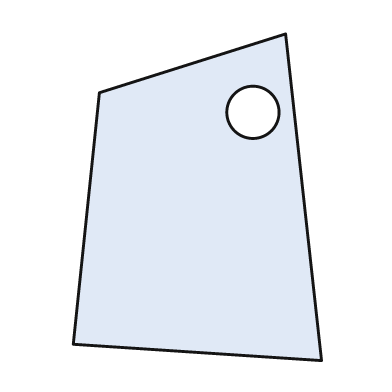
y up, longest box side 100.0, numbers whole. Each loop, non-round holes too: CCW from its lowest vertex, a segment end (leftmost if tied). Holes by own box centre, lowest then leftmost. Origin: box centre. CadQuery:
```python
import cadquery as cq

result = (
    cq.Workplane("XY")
    .moveTo(38.0, -50.0)
    .lineTo(27.0, 50.0)
    .lineTo(-30.0, 32.0)
    .lineTo(-38.0, -45.0)
    .close()
    .moveTo(17.0, 26.0)
    .circle(8.0)
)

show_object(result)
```